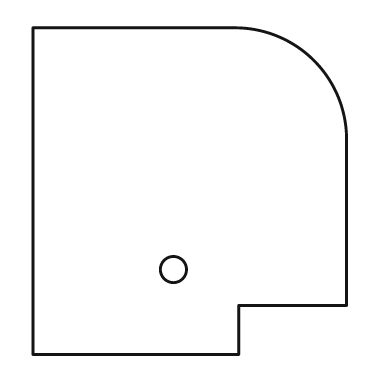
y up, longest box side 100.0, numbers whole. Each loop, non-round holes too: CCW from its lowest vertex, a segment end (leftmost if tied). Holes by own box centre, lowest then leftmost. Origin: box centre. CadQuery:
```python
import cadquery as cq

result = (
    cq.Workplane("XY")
    .moveTo(-48.0, -50.0)
    .lineTo(15.0, -50.0)
    .lineTo(15.0, -35.0)
    .lineTo(48.0, -35.0)
    .lineTo(48.0, 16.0)
    .threePointArc((38.0, 40.0), (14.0, 50.0))
    .lineTo(-48.0, 50.0)
    .close()
    .moveTo(-5.0, -24.0)
    .circle(4.0)
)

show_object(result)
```